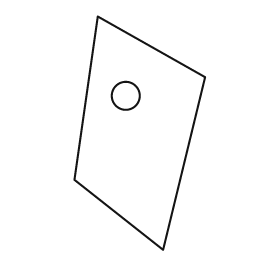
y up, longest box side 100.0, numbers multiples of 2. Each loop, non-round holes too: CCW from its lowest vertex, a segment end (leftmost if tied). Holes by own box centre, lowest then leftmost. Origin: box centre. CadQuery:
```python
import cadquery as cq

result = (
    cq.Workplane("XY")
    .moveTo(10.0, -50.0)
    .lineTo(28.0, 24.0)
    .lineTo(-18.0, 50.0)
    .lineTo(-28.0, -20.0)
    .close()
    .moveTo(-6.0, 16.0)
    .circle(6.0)
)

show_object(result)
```